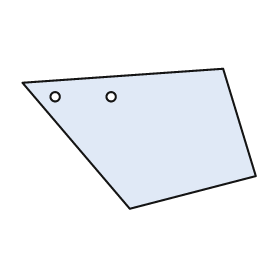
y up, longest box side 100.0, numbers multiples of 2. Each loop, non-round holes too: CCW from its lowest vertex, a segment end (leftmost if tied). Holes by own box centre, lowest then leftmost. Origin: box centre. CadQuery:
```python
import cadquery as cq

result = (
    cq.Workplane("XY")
    .moveTo(-4.0, -30.0)
    .lineTo(50.0, -16.0)
    .lineTo(36.0, 30.0)
    .lineTo(-50.0, 24.0)
    .close()
    .moveTo(-36.0, 18.0)
    .circle(2.0)
    .moveTo(-12.0, 18.0)
    .circle(2.0)
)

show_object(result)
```